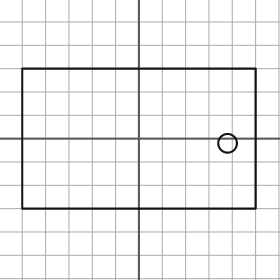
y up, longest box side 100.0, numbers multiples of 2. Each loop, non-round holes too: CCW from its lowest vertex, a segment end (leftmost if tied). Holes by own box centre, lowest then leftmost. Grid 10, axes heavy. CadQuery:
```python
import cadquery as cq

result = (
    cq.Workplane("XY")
    .moveTo(-50.0, -30.0)
    .lineTo(50.0, -30.0)
    .lineTo(50.0, 30.0)
    .lineTo(-50.0, 30.0)
    .close()
    .moveTo(38.0, -2.0)
    .circle(4.0)
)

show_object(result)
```